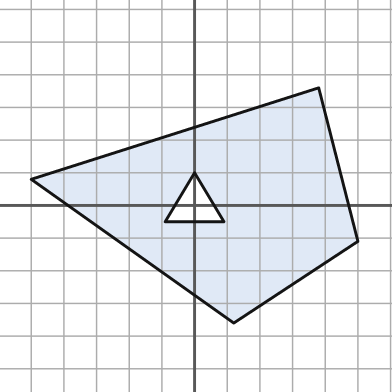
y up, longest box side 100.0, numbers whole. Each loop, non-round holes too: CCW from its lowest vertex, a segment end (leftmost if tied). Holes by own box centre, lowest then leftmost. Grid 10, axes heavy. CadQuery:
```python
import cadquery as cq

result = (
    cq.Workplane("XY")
    .moveTo(12.0, -36.0)
    .lineTo(50.0, -11.0)
    .lineTo(38.0, 36.0)
    .lineTo(-50.0, 8.0)
    .close()
    .moveTo(-9.0, -5.0)
    .lineTo(9.0, -5.0)
    .lineTo(0.0, 10.0)
    .close()
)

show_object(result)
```